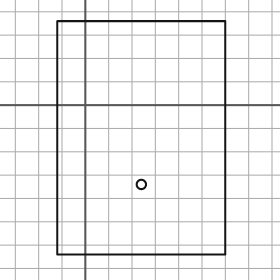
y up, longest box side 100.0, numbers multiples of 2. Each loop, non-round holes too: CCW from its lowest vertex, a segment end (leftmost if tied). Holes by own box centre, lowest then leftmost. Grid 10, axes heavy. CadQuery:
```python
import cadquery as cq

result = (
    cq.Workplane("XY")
    .moveTo(-12.0, -64.0)
    .lineTo(60.0, -64.0)
    .lineTo(60.0, 36.0)
    .lineTo(-12.0, 36.0)
    .close()
    .moveTo(24.0, -34.0)
    .circle(2.0)
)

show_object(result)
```